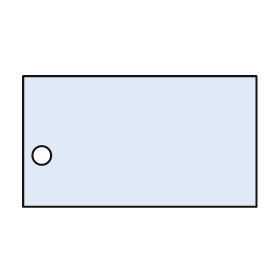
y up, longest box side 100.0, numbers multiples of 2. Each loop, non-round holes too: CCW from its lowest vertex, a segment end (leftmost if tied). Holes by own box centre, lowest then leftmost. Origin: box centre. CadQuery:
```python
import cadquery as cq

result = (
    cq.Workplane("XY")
    .moveTo(-50.0, -28.0)
    .lineTo(50.0, -28.0)
    .lineTo(50.0, 28.0)
    .lineTo(-50.0, 28.0)
    .close()
    .moveTo(-42.0, -6.0)
    .circle(4.0)
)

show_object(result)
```